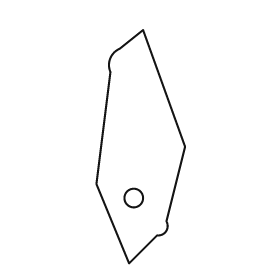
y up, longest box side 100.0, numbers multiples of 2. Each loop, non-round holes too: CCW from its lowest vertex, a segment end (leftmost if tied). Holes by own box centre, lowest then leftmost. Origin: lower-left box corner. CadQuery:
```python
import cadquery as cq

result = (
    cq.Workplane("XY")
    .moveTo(14.0, 0.0)
    .lineTo(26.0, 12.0)
    .threePointArc((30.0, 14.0), (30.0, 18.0))
    .lineTo(38.0, 50.0)
    .lineTo(20.0, 100.0)
    .lineTo(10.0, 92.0)
    .threePointArc((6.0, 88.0), (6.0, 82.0))
    .lineTo(0.0, 34.0)
    .close()
    .moveTo(16.0, 28.0)
    .circle(4.0)
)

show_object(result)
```